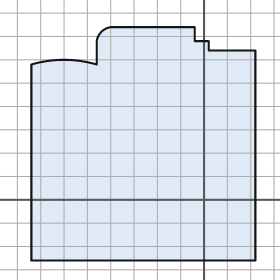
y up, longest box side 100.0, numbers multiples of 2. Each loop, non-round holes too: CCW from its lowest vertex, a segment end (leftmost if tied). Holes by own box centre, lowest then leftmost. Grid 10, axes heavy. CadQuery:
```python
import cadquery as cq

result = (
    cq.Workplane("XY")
    .moveTo(-74.0, -26.0)
    .lineTo(22.0, -26.0)
    .lineTo(22.0, 64.0)
    .lineTo(2.0, 64.0)
    .lineTo(2.0, 68.0)
    .lineTo(-4.0, 68.0)
    .lineTo(-4.0, 74.0)
    .lineTo(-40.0, 74.0)
    .threePointArc((-44.0, 72.0), (-46.0, 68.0))
    .lineTo(-46.0, 58.0)
    .threePointArc((-60.0, 60.0), (-74.0, 58.0))
    .close()
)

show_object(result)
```